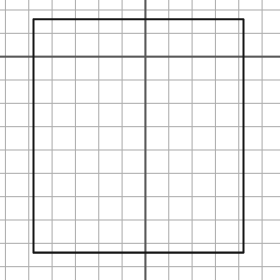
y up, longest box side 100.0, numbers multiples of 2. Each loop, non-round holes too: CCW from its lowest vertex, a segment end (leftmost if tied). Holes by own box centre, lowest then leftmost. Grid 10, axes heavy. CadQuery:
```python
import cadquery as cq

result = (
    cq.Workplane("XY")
    .moveTo(-48.0, -84.0)
    .lineTo(42.0, -84.0)
    .lineTo(42.0, 16.0)
    .lineTo(-48.0, 16.0)
    .close()
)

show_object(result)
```